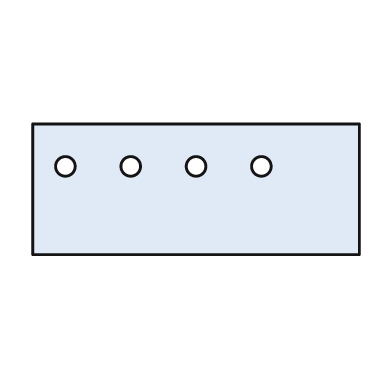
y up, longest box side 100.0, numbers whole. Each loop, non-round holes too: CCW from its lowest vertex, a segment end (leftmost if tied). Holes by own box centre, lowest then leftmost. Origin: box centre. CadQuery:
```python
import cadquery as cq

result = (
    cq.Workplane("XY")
    .moveTo(-50.0, -20.0)
    .lineTo(50.0, -20.0)
    .lineTo(50.0, 20.0)
    .lineTo(-50.0, 20.0)
    .close()
    .moveTo(-40.0, 7.0)
    .circle(3.0)
    .moveTo(-20.0, 7.0)
    .circle(3.0)
    .moveTo(0.0, 7.0)
    .circle(3.0)
    .moveTo(20.0, 7.0)
    .circle(3.0)
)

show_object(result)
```